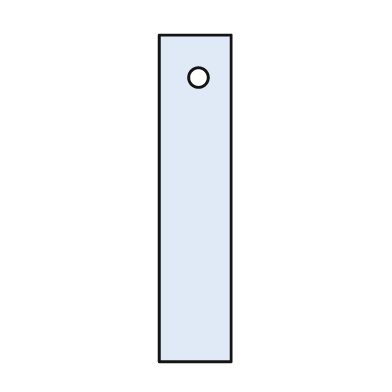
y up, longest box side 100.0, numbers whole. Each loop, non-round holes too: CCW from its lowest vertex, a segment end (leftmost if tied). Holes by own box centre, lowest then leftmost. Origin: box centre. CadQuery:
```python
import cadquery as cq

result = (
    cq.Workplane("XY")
    .moveTo(-11.0, -50.0)
    .lineTo(11.0, -50.0)
    .lineTo(11.0, 50.0)
    .lineTo(-11.0, 50.0)
    .close()
    .moveTo(1.0, 37.0)
    .circle(3.0)
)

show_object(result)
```